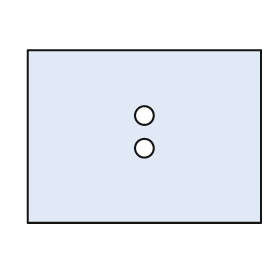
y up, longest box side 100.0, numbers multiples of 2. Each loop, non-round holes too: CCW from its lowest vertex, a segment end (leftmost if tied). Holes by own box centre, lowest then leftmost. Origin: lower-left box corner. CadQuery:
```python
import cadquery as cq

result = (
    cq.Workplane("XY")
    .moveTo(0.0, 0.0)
    .lineTo(100.0, 0.0)
    .lineTo(100.0, 74.0)
    .lineTo(0.0, 74.0)
    .close()
    .moveTo(50.0, 32.0)
    .circle(4.0)
    .moveTo(50.0, 46.0)
    .circle(4.0)
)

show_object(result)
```